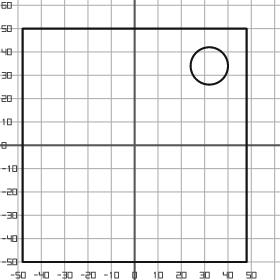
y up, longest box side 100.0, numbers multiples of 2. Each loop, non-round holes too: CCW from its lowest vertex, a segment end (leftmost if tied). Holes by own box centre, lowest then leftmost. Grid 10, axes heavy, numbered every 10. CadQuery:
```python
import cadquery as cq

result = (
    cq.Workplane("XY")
    .moveTo(-48.0, -50.0)
    .lineTo(48.0, -50.0)
    .lineTo(48.0, 50.0)
    .lineTo(-48.0, 50.0)
    .close()
    .moveTo(32.0, 34.0)
    .circle(8.0)
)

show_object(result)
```